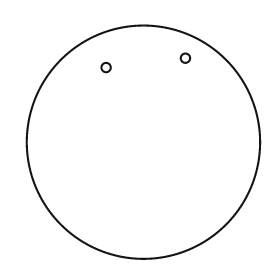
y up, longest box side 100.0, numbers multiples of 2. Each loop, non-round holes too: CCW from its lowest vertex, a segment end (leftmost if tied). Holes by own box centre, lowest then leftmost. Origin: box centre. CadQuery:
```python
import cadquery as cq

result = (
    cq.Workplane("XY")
    .moveTo(0.0, 0.0)
    .circle(50.0)
    .moveTo(-16.0, 32.0)
    .circle(2.0)
    .moveTo(18.0, 36.0)
    .circle(2.0)
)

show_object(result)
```